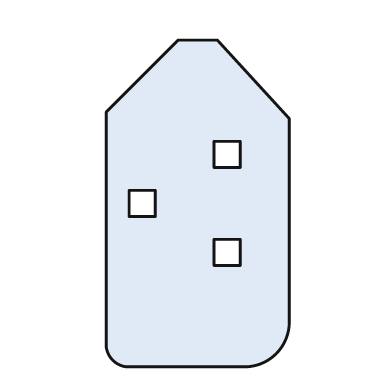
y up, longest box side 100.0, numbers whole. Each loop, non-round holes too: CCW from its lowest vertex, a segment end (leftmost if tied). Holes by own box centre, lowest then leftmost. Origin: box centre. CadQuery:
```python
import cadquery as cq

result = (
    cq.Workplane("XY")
    .moveTo(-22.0, -50.0)
    .lineTo(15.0, -50.0)
    .threePointArc((24.0, -46.0), (28.0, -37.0))
    .lineTo(28.0, 26.0)
    .lineTo(6.0, 50.0)
    .lineTo(-6.0, 50.0)
    .lineTo(-28.0, 28.0)
    .lineTo(-28.0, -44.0)
    .threePointArc((-26.0, -48.0), (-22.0, -50.0))
    .close()
    .moveTo(5.0, -19.0)
    .lineTo(13.0, -19.0)
    .lineTo(13.0, -11.0)
    .lineTo(5.0, -11.0)
    .close()
    .moveTo(-21.0, -4.0)
    .lineTo(-13.0, -4.0)
    .lineTo(-13.0, 4.0)
    .lineTo(-21.0, 4.0)
    .close()
    .moveTo(5.0, 11.0)
    .lineTo(13.0, 11.0)
    .lineTo(13.0, 19.0)
    .lineTo(5.0, 19.0)
    .close()
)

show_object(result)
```